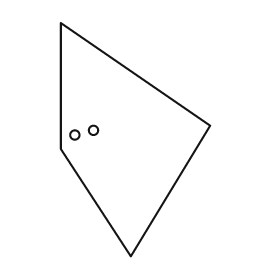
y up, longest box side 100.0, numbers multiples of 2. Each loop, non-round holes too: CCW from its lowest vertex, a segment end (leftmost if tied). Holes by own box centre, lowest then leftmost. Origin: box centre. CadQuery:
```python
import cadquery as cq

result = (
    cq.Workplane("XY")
    .moveTo(-2.0, -50.0)
    .lineTo(32.0, 6.0)
    .lineTo(-32.0, 50.0)
    .lineTo(-32.0, -4.0)
    .close()
    .moveTo(-26.0, 2.0)
    .circle(2.0)
    .moveTo(-18.0, 4.0)
    .circle(2.0)
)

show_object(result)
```